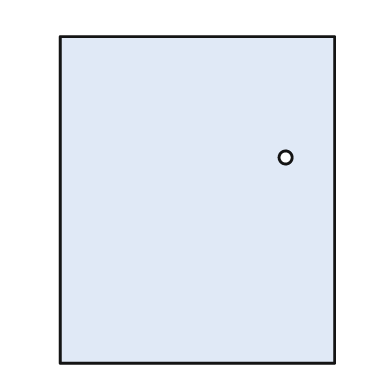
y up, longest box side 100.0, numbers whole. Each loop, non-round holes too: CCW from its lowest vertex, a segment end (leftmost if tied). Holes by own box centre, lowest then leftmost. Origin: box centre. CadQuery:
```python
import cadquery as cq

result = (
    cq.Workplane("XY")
    .moveTo(-42.0, -50.0)
    .lineTo(42.0, -50.0)
    .lineTo(42.0, 50.0)
    .lineTo(-42.0, 50.0)
    .close()
    .moveTo(27.0, 13.0)
    .circle(2.0)
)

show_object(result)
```